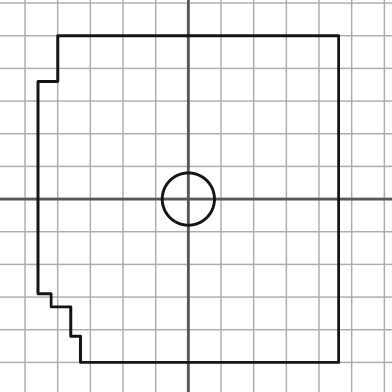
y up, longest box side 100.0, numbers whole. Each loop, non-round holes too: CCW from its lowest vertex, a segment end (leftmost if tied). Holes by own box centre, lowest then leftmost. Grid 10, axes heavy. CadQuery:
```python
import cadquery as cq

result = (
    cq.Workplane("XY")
    .moveTo(-33.0, -50.0)
    .lineTo(46.0, -50.0)
    .lineTo(46.0, 50.0)
    .lineTo(-40.0, 50.0)
    .lineTo(-40.0, 36.0)
    .lineTo(-46.0, 36.0)
    .lineTo(-46.0, -29.0)
    .lineTo(-42.0, -29.0)
    .lineTo(-42.0, -33.0)
    .lineTo(-36.0, -33.0)
    .lineTo(-36.0, -42.0)
    .lineTo(-33.0, -42.0)
    .close()
    .moveTo(0.0, 0.0)
    .circle(8.0)
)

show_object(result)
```